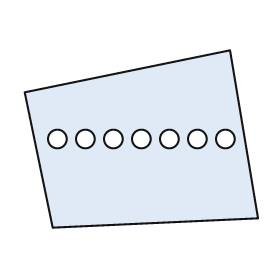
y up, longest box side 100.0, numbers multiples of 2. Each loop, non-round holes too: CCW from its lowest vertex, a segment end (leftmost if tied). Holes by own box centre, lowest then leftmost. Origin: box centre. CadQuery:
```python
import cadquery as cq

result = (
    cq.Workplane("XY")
    .moveTo(-38.0, -38.0)
    .lineTo(50.0, -34.0)
    .lineTo(38.0, 38.0)
    .lineTo(-50.0, 20.0)
    .close()
    .moveTo(-36.0, 0.0)
    .circle(4.0)
    .moveTo(-24.0, 0.0)
    .circle(4.0)
    .moveTo(-12.0, 0.0)
    .circle(4.0)
    .moveTo(0.0, 0.0)
    .circle(4.0)
    .moveTo(12.0, 0.0)
    .circle(4.0)
    .moveTo(24.0, 0.0)
    .circle(4.0)
    .moveTo(36.0, 0.0)
    .circle(4.0)
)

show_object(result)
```